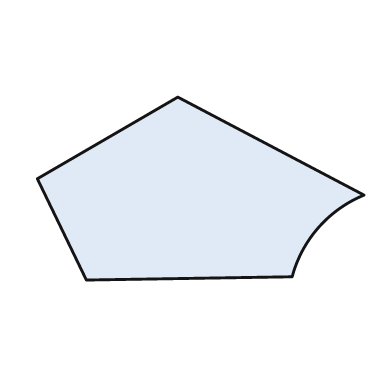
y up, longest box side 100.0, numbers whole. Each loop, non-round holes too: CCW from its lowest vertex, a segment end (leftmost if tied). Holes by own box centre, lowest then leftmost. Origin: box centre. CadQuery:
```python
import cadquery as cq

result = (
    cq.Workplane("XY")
    .moveTo(-35.0, -28.0)
    .lineTo(28.0, -27.0)
    .threePointArc((36.0, -12.0), (50.0, -2.0))
    .lineTo(-7.0, 28.0)
    .lineTo(-50.0, 3.0)
    .close()
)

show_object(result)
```